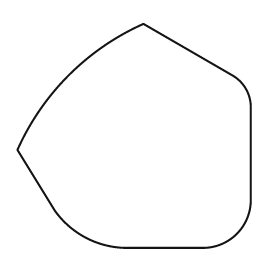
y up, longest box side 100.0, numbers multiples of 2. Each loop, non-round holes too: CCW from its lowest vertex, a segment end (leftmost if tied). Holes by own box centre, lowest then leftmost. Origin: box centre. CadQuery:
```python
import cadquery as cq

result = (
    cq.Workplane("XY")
    .moveTo(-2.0, -48.0)
    .lineTo(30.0, -48.0)
    .threePointArc((44.0, -42.0), (50.0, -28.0))
    .lineTo(50.0, 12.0)
    .threePointArc((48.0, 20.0), (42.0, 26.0))
    .lineTo(4.0, 48.0)
    .threePointArc((-28.0, 26.0), (-50.0, -6.0))
    .lineTo(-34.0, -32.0)
    .threePointArc((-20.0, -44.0), (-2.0, -48.0))
    .close()
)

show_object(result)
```